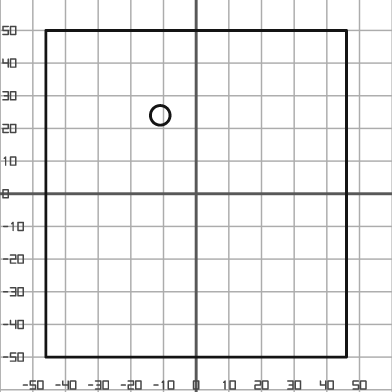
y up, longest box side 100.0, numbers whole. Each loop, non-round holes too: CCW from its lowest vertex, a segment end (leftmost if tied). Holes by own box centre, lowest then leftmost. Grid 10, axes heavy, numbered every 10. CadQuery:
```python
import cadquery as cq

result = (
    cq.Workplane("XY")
    .moveTo(-46.0, -50.0)
    .lineTo(46.0, -50.0)
    .lineTo(46.0, 50.0)
    .lineTo(-46.0, 50.0)
    .close()
    .moveTo(-11.0, 24.0)
    .circle(3.0)
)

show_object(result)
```